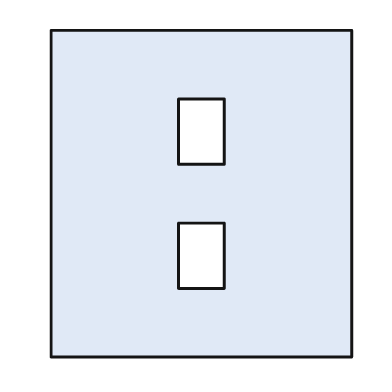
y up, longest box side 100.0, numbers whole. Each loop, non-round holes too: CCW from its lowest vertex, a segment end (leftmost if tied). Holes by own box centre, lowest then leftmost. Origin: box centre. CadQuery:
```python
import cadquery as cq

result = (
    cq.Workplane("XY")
    .moveTo(-46.0, -50.0)
    .lineTo(46.0, -50.0)
    .lineTo(46.0, 50.0)
    .lineTo(-46.0, 50.0)
    .close()
    .moveTo(-7.0, -29.0)
    .lineTo(7.0, -29.0)
    .lineTo(7.0, -9.0)
    .lineTo(-7.0, -9.0)
    .close()
    .moveTo(-7.0, 9.0)
    .lineTo(7.0, 9.0)
    .lineTo(7.0, 29.0)
    .lineTo(-7.0, 29.0)
    .close()
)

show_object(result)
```